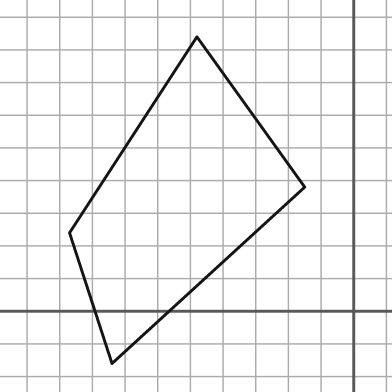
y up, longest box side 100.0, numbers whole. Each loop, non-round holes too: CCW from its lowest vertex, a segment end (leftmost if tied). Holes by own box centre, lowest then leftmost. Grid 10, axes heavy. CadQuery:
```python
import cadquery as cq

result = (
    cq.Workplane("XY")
    .moveTo(-74.0, -16.0)
    .lineTo(-15.0, 38.0)
    .lineTo(-48.0, 84.0)
    .lineTo(-87.0, 24.0)
    .close()
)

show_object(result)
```